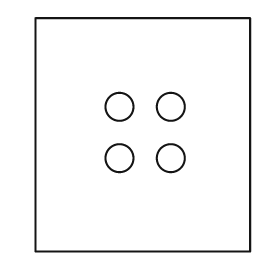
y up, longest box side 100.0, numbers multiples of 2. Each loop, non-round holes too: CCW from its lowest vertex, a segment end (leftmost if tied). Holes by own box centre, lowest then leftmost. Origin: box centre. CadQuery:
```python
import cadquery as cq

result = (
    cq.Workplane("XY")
    .moveTo(-46.0, -50.0)
    .lineTo(46.0, -50.0)
    .lineTo(46.0, 50.0)
    .lineTo(-46.0, 50.0)
    .close()
    .moveTo(-10.0, -10.0)
    .circle(6.0)
    .moveTo(12.0, -10.0)
    .circle(6.0)
    .moveTo(-10.0, 12.0)
    .circle(6.0)
    .moveTo(12.0, 12.0)
    .circle(6.0)
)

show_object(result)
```